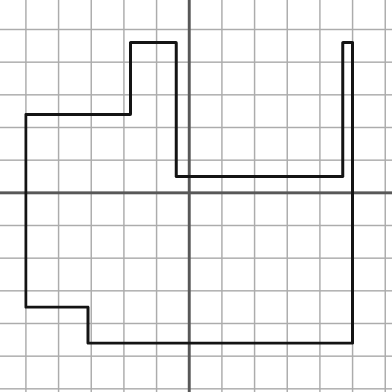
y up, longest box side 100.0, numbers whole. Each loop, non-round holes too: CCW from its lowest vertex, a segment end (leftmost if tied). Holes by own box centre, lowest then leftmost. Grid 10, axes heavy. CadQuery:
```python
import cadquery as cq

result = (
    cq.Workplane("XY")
    .moveTo(-31.0, -46.0)
    .lineTo(50.0, -46.0)
    .lineTo(50.0, 46.0)
    .lineTo(47.0, 46.0)
    .lineTo(47.0, 5.0)
    .lineTo(-4.0, 5.0)
    .lineTo(-4.0, 46.0)
    .lineTo(-18.0, 46.0)
    .lineTo(-18.0, 24.0)
    .lineTo(-50.0, 24.0)
    .lineTo(-50.0, -35.0)
    .lineTo(-31.0, -35.0)
    .close()
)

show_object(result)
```